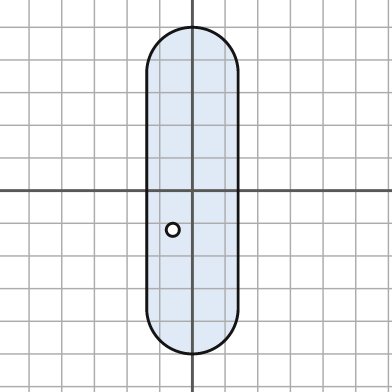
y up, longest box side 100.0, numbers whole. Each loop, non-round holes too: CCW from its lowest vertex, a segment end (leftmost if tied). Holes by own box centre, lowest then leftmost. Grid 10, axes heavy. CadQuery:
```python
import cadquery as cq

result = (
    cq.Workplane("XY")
    .moveTo(-14.0, -36.0)
    .threePointArc((0.0, -50.0), (14.0, -36.0))
    .lineTo(14.0, 36.0)
    .threePointArc((0.0, 50.0), (-14.0, 36.0))
    .close()
    .moveTo(-6.0, -12.0)
    .circle(2.0)
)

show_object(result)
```